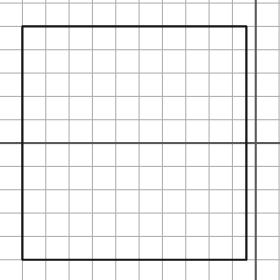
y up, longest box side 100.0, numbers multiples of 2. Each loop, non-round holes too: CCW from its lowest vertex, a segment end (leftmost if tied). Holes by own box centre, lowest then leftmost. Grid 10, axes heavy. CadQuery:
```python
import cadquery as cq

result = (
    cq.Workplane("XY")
    .moveTo(-100.0, -50.0)
    .lineTo(-4.0, -50.0)
    .lineTo(-4.0, 50.0)
    .lineTo(-100.0, 50.0)
    .close()
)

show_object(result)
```